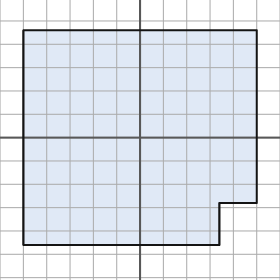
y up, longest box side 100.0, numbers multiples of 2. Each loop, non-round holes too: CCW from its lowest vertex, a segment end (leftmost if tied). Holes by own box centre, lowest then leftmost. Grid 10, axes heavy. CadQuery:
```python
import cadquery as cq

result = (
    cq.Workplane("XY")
    .moveTo(-50.0, -46.0)
    .lineTo(34.0, -46.0)
    .lineTo(34.0, -28.0)
    .lineTo(50.0, -28.0)
    .lineTo(50.0, 46.0)
    .lineTo(-50.0, 46.0)
    .close()
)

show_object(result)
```